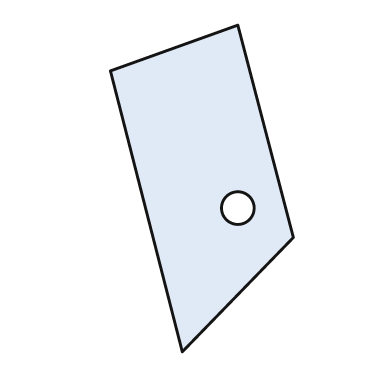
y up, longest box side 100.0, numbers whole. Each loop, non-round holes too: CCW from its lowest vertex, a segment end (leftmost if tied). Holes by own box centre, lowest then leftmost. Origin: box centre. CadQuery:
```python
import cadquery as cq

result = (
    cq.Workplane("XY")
    .moveTo(-6.0, -50.0)
    .lineTo(28.0, -15.0)
    .lineTo(11.0, 50.0)
    .lineTo(-28.0, 36.0)
    .close()
    .moveTo(11.0, -6.0)
    .circle(5.0)
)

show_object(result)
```